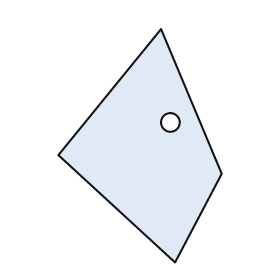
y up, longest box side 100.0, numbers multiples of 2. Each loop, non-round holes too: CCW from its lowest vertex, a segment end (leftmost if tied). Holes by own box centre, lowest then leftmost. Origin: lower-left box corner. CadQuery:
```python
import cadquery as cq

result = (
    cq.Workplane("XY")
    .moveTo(50.0, 0.0)
    .lineTo(70.0, 38.0)
    .lineTo(44.0, 100.0)
    .lineTo(0.0, 46.0)
    .close()
    .moveTo(48.0, 60.0)
    .circle(4.0)
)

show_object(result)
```